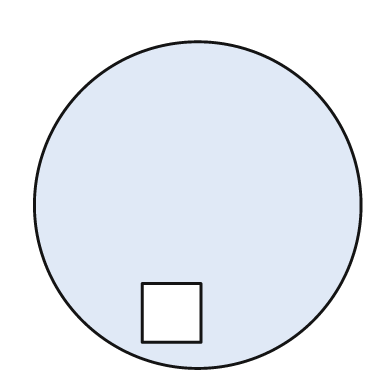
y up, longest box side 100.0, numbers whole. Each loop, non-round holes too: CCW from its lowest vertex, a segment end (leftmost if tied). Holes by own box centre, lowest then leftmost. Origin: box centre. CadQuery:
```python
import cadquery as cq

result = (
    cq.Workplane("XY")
    .moveTo(0.0, 0.0)
    .circle(50.0)
    .moveTo(-17.0, -42.0)
    .lineTo(1.0, -42.0)
    .lineTo(1.0, -24.0)
    .lineTo(-17.0, -24.0)
    .close()
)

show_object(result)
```